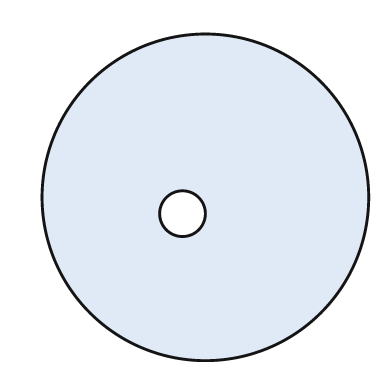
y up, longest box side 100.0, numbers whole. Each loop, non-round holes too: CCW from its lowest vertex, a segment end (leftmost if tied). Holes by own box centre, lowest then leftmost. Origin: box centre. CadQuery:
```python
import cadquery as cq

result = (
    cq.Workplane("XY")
    .moveTo(0.0, 0.0)
    .circle(50.0)
    .moveTo(-7.0, -5.0)
    .circle(7.0)
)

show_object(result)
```